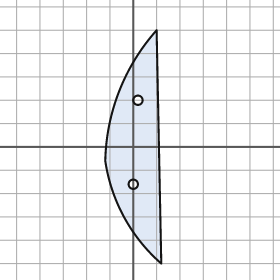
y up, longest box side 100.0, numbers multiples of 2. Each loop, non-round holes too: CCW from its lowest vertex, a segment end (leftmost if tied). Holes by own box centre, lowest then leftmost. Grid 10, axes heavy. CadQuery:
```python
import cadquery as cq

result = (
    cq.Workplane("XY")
    .moveTo(12.0, -50.0)
    .lineTo(10.0, 50.0)
    .threePointArc((-6.0, 24.0), (-12.0, -6.0))
    .threePointArc((-4.0, -30.0), (12.0, -50.0))
    .close()
    .moveTo(0.0, -16.0)
    .circle(2.0)
    .moveTo(2.0, 20.0)
    .circle(2.0)
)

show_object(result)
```